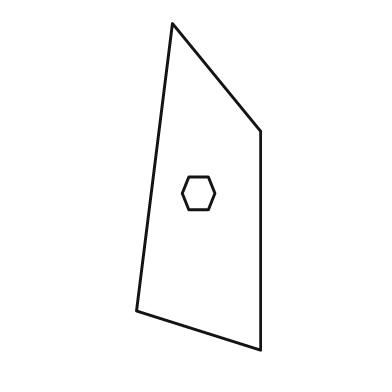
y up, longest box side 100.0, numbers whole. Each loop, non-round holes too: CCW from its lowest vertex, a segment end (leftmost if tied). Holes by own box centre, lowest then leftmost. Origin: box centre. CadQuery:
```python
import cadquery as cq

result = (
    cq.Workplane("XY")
    .moveTo(19.0, -50.0)
    .lineTo(19.0, 17.0)
    .lineTo(-8.0, 50.0)
    .lineTo(-19.0, -38.0)
    .close()
    .moveTo(-3.0, -7.0)
    .lineTo(3.0, -7.0)
    .lineTo(5.0, -2.0)
    .lineTo(3.0, 3.0)
    .lineTo(-3.0, 3.0)
    .lineTo(-5.0, -2.0)
    .close()
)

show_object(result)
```